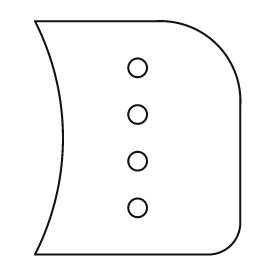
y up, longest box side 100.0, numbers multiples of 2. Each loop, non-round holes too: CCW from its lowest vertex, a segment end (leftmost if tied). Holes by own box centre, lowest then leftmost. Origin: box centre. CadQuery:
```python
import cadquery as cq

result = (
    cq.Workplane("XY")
    .moveTo(-44.0, -50.0)
    .lineTo(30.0, -50.0)
    .threePointArc((40.0, -46.0), (44.0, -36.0))
    .lineTo(44.0, 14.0)
    .threePointArc((34.0, 40.0), (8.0, 50.0))
    .lineTo(-44.0, 50.0)
    .threePointArc((-32.0, 0.0), (-44.0, -50.0))
    .close()
    .moveTo(0.0, -30.0)
    .circle(4.0)
    .moveTo(0.0, -10.0)
    .circle(4.0)
    .moveTo(0.0, 10.0)
    .circle(4.0)
    .moveTo(0.0, 30.0)
    .circle(4.0)
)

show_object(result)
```